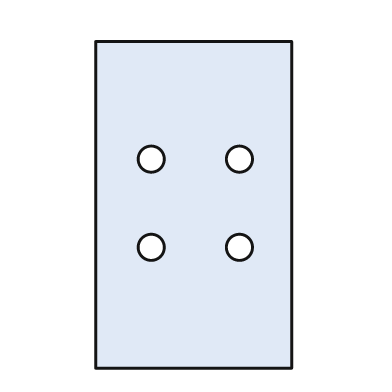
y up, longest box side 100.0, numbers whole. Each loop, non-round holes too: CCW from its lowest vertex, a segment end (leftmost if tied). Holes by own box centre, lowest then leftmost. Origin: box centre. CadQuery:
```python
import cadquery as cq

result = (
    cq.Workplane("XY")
    .moveTo(-30.0, -50.0)
    .lineTo(30.0, -50.0)
    .lineTo(30.0, 50.0)
    .lineTo(-30.0, 50.0)
    .close()
    .moveTo(-13.0, -13.0)
    .circle(4.0)
    .moveTo(14.0, -13.0)
    .circle(4.0)
    .moveTo(-13.0, 14.0)
    .circle(4.0)
    .moveTo(14.0, 14.0)
    .circle(4.0)
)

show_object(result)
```